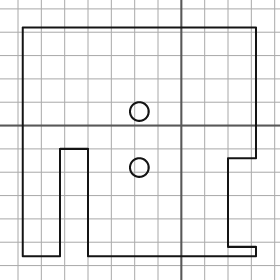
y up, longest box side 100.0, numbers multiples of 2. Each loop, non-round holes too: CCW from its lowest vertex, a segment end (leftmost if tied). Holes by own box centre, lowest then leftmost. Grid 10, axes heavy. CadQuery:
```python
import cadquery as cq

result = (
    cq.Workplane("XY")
    .moveTo(-68.0, -56.0)
    .lineTo(-52.0, -56.0)
    .lineTo(-52.0, -10.0)
    .lineTo(-40.0, -10.0)
    .lineTo(-40.0, -56.0)
    .lineTo(32.0, -56.0)
    .lineTo(32.0, -52.0)
    .lineTo(20.0, -52.0)
    .lineTo(20.0, -14.0)
    .lineTo(32.0, -14.0)
    .lineTo(32.0, 42.0)
    .lineTo(-68.0, 42.0)
    .close()
    .moveTo(-18.0, -18.0)
    .circle(4.0)
    .moveTo(-18.0, 6.0)
    .circle(4.0)
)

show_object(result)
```